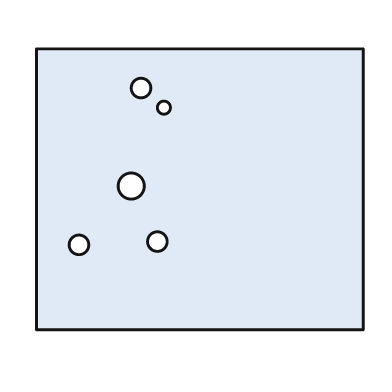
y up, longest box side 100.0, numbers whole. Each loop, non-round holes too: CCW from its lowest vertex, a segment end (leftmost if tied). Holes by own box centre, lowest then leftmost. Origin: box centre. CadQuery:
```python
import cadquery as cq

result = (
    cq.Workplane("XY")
    .moveTo(-50.0, -43.0)
    .lineTo(50.0, -43.0)
    .lineTo(50.0, 43.0)
    .lineTo(-50.0, 43.0)
    .close()
    .moveTo(-37.0, -17.0)
    .circle(3.0)
    .moveTo(-13.0, -16.0)
    .circle(3.0)
    .moveTo(-21.0, 1.0)
    .circle(4.0)
    .moveTo(-11.0, 25.0)
    .circle(2.0)
    .moveTo(-18.0, 31.0)
    .circle(3.0)
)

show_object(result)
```